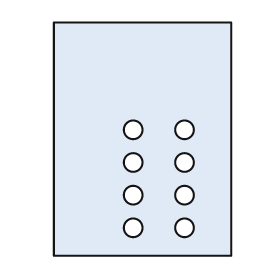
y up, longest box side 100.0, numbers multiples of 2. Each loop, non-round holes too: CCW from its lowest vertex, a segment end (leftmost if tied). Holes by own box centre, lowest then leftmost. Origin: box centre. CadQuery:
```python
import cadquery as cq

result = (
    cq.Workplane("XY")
    .moveTo(-38.0, -50.0)
    .lineTo(38.0, -50.0)
    .lineTo(38.0, 50.0)
    .lineTo(-38.0, 50.0)
    .close()
    .moveTo(-4.0, -38.0)
    .circle(4.0)
    .moveTo(18.0, -38.0)
    .circle(4.0)
    .moveTo(-4.0, -24.0)
    .circle(4.0)
    .moveTo(18.0, -24.0)
    .circle(4.0)
    .moveTo(-4.0, -10.0)
    .circle(4.0)
    .moveTo(18.0, -10.0)
    .circle(4.0)
    .moveTo(-4.0, 4.0)
    .circle(4.0)
    .moveTo(18.0, 4.0)
    .circle(4.0)
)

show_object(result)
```